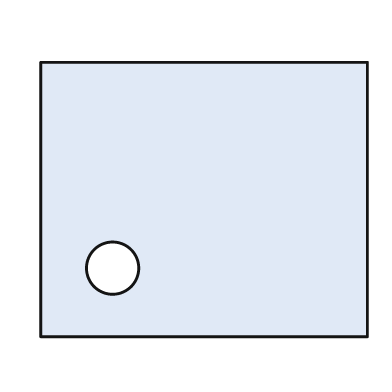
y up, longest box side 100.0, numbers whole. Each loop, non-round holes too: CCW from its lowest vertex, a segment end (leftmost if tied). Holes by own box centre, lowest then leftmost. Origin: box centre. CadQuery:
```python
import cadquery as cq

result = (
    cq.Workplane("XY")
    .moveTo(-50.0, -42.0)
    .lineTo(50.0, -42.0)
    .lineTo(50.0, 42.0)
    .lineTo(-50.0, 42.0)
    .close()
    .moveTo(-28.0, -21.0)
    .circle(8.0)
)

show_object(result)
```